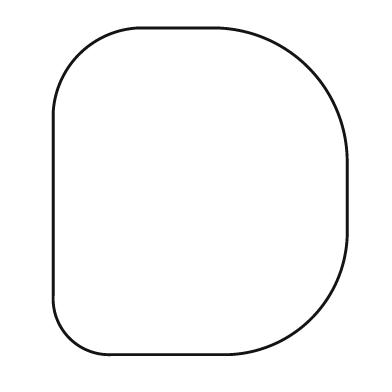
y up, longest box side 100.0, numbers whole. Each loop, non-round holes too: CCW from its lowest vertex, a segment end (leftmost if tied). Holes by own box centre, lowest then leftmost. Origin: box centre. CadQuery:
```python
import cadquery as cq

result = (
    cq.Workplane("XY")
    .moveTo(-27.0, -50.0)
    .lineTo(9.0, -50.0)
    .threePointArc((34.0, -39.0), (45.0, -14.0))
    .lineTo(45.0, 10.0)
    .threePointArc((33.0, 38.0), (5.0, 50.0))
    .lineTo(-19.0, 50.0)
    .threePointArc((-37.0, 42.0), (-45.0, 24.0))
    .lineTo(-45.0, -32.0)
    .threePointArc((-40.0, -45.0), (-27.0, -50.0))
    .close()
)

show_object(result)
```